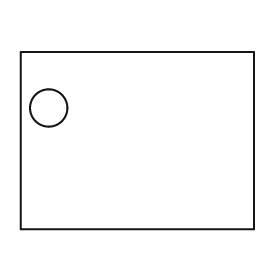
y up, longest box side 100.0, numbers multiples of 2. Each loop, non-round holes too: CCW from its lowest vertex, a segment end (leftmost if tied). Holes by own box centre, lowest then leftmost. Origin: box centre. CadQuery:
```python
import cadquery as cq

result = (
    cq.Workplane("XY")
    .moveTo(-50.0, -38.0)
    .lineTo(50.0, -38.0)
    .lineTo(50.0, 38.0)
    .lineTo(-50.0, 38.0)
    .close()
    .moveTo(-38.0, 14.0)
    .circle(8.0)
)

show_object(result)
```